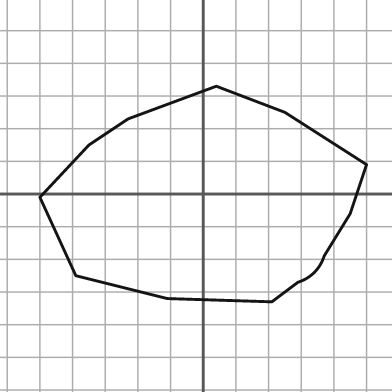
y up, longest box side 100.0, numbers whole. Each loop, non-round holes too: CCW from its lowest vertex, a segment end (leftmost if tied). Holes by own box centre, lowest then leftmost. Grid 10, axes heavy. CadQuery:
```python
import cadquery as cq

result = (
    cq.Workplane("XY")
    .moveTo(21.0, -33.0)
    .lineTo(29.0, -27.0)
    .threePointArc((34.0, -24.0), (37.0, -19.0))
    .lineTo(45.0, -6.0)
    .lineTo(50.0, 9.0)
    .lineTo(25.0, 25.0)
    .lineTo(4.0, 33.0)
    .lineTo(-23.0, 23.0)
    .lineTo(-35.0, 15.0)
    .lineTo(-50.0, -1.0)
    .lineTo(-39.0, -25.0)
    .lineTo(-11.0, -32.0)
    .close()
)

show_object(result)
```